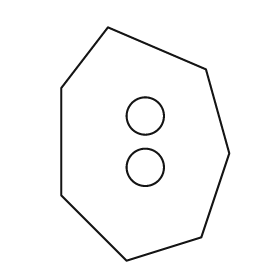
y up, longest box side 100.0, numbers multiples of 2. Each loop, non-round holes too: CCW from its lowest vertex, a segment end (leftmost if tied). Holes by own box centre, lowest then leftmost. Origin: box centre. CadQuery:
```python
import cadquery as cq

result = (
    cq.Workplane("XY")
    .moveTo(-8.0, -50.0)
    .lineTo(24.0, -40.0)
    .lineTo(36.0, -4.0)
    .lineTo(26.0, 32.0)
    .lineTo(-16.0, 50.0)
    .lineTo(-36.0, 24.0)
    .lineTo(-36.0, -22.0)
    .close()
    .moveTo(0.0, -10.0)
    .circle(8.0)
    .moveTo(0.0, 12.0)
    .circle(8.0)
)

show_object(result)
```